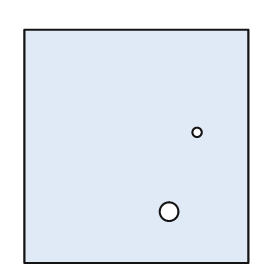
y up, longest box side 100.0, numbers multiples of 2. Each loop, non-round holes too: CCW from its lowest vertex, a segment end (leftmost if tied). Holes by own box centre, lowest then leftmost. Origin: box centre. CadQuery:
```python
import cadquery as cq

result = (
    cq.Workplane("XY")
    .moveTo(-48.0, -50.0)
    .lineTo(48.0, -50.0)
    .lineTo(48.0, 50.0)
    .lineTo(-48.0, 50.0)
    .close()
    .moveTo(14.0, -28.0)
    .circle(4.0)
    .moveTo(26.0, 6.0)
    .circle(2.0)
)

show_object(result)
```